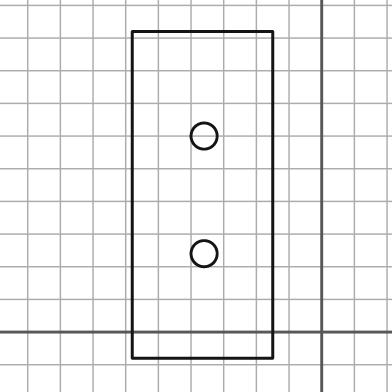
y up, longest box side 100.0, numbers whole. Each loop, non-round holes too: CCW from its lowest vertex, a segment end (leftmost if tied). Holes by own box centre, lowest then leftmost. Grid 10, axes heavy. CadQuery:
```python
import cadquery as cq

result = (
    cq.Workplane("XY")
    .moveTo(-58.0, -8.0)
    .lineTo(-15.0, -8.0)
    .lineTo(-15.0, 92.0)
    .lineTo(-58.0, 92.0)
    .close()
    .moveTo(-36.0, 24.0)
    .circle(4.0)
    .moveTo(-36.0, 60.0)
    .circle(4.0)
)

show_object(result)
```